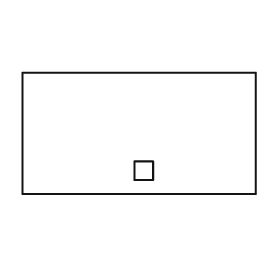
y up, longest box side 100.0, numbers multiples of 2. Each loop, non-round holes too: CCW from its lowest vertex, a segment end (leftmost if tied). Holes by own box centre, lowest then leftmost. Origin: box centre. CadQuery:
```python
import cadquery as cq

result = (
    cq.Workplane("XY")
    .moveTo(-50.0, -26.0)
    .lineTo(50.0, -26.0)
    .lineTo(50.0, 26.0)
    .lineTo(-50.0, 26.0)
    .close()
    .moveTo(-2.0, -20.0)
    .lineTo(6.0, -20.0)
    .lineTo(6.0, -12.0)
    .lineTo(-2.0, -12.0)
    .close()
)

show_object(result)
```